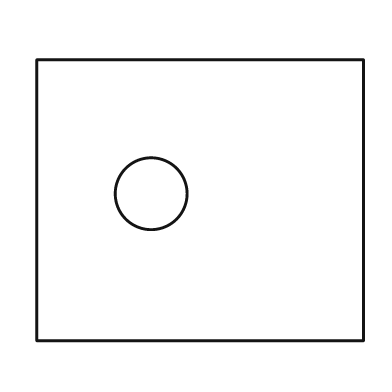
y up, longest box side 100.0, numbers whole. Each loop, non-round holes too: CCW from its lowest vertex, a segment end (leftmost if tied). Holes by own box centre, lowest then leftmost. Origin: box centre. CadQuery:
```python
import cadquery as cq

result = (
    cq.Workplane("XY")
    .moveTo(-50.0, -43.0)
    .lineTo(50.0, -43.0)
    .lineTo(50.0, 43.0)
    .lineTo(-50.0, 43.0)
    .close()
    .moveTo(-15.0, 2.0)
    .circle(11.0)
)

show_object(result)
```